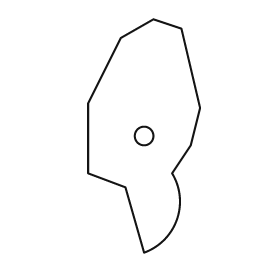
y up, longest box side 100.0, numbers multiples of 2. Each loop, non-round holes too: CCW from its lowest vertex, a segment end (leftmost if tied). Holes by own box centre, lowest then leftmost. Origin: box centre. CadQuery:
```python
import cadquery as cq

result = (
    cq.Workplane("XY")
    .moveTo(0.0, -50.0)
    .threePointArc((14.0, -36.0), (12.0, -16.0))
    .lineTo(20.0, -4.0)
    .lineTo(24.0, 12.0)
    .lineTo(16.0, 46.0)
    .lineTo(4.0, 50.0)
    .lineTo(-10.0, 42.0)
    .lineTo(-24.0, 14.0)
    .lineTo(-24.0, -16.0)
    .lineTo(-8.0, -22.0)
    .close()
    .moveTo(0.0, 0.0)
    .circle(4.0)
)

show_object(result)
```